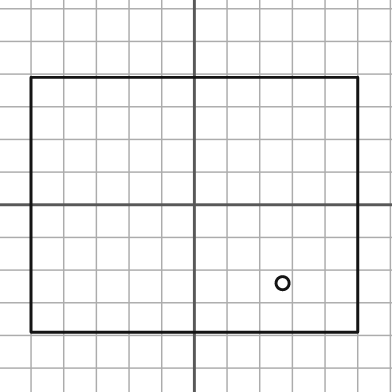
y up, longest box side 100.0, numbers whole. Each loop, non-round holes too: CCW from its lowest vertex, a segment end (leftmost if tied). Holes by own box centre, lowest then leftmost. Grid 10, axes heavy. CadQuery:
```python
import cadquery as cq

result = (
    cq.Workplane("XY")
    .moveTo(-50.0, -39.0)
    .lineTo(50.0, -39.0)
    .lineTo(50.0, 39.0)
    .lineTo(-50.0, 39.0)
    .close()
    .moveTo(27.0, -24.0)
    .circle(2.0)
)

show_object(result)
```